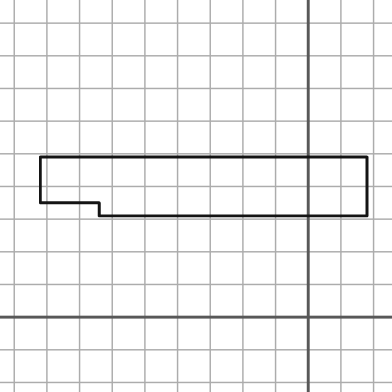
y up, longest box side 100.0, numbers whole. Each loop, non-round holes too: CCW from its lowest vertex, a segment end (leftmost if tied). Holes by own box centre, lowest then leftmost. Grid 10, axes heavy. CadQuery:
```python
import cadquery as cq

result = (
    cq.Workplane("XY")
    .moveTo(-64.0, 31.0)
    .lineTo(18.0, 31.0)
    .lineTo(18.0, 49.0)
    .lineTo(-82.0, 49.0)
    .lineTo(-82.0, 35.0)
    .lineTo(-64.0, 35.0)
    .close()
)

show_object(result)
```